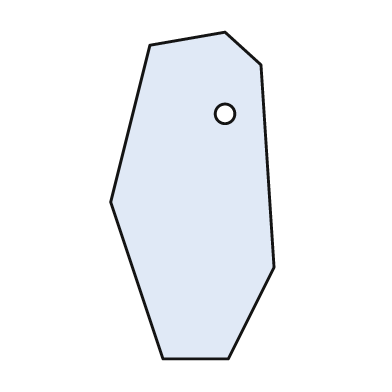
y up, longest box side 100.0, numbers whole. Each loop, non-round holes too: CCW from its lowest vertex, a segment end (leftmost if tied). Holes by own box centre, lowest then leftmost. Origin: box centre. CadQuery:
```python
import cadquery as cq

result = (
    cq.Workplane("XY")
    .moveTo(-9.0, -50.0)
    .lineTo(11.0, -50.0)
    .lineTo(25.0, -22.0)
    .lineTo(21.0, 40.0)
    .lineTo(10.0, 50.0)
    .lineTo(-13.0, 46.0)
    .lineTo(-25.0, -2.0)
    .close()
    .moveTo(10.0, 25.0)
    .circle(3.0)
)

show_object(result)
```